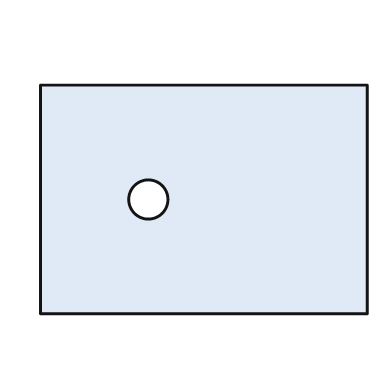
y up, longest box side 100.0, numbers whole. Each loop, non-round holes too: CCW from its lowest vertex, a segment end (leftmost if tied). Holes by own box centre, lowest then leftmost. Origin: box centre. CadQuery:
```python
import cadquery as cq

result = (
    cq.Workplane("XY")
    .moveTo(-50.0, -35.0)
    .lineTo(50.0, -35.0)
    .lineTo(50.0, 35.0)
    .lineTo(-50.0, 35.0)
    .close()
    .moveTo(-17.0, 0.0)
    .circle(6.0)
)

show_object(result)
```